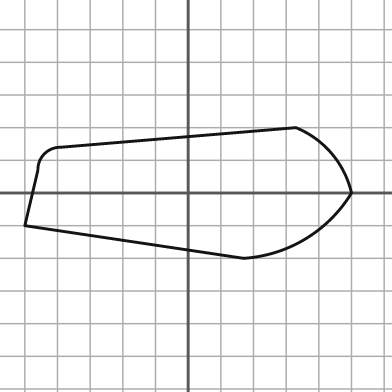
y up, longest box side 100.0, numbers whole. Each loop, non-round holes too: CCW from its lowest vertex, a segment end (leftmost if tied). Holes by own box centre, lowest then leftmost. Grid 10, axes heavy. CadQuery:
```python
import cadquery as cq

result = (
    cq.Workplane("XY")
    .moveTo(17.0, -20.0)
    .threePointArc((36.0, -14.0), (50.0, 0.0))
    .threePointArc((44.0, 12.0), (33.0, 20.0))
    .lineTo(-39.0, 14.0)
    .threePointArc((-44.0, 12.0), (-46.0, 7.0))
    .lineTo(-50.0, -10.0)
    .close()
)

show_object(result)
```